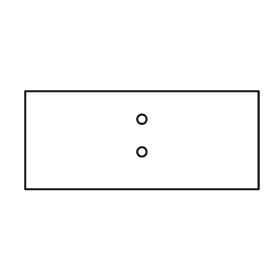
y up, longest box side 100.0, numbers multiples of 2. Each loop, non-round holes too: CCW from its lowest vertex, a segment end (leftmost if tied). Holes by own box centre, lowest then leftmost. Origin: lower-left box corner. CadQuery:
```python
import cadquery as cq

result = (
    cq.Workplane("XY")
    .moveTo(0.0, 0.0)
    .lineTo(100.0, 0.0)
    .lineTo(100.0, 42.0)
    .lineTo(0.0, 42.0)
    .close()
    .moveTo(50.0, 16.0)
    .circle(2.0)
    .moveTo(50.0, 30.0)
    .circle(2.0)
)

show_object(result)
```